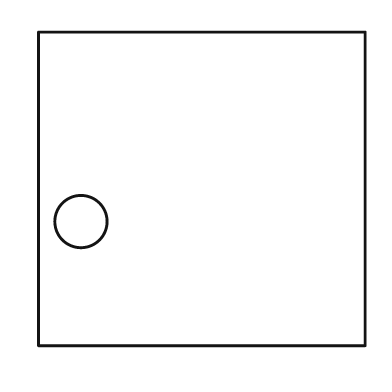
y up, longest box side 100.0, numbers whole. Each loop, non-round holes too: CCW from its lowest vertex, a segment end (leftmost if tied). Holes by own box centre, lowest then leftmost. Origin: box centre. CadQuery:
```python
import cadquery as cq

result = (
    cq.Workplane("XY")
    .moveTo(-50.0, -48.0)
    .lineTo(50.0, -48.0)
    .lineTo(50.0, 48.0)
    .lineTo(-50.0, 48.0)
    .close()
    .moveTo(-37.0, -10.0)
    .circle(8.0)
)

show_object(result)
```